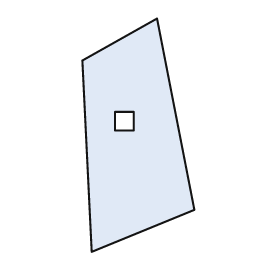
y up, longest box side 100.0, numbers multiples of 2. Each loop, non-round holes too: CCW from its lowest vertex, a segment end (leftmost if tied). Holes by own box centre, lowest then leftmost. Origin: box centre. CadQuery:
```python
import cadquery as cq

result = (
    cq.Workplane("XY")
    .moveTo(-20.0, -50.0)
    .lineTo(24.0, -32.0)
    .lineTo(8.0, 50.0)
    .lineTo(-24.0, 32.0)
    .close()
    .moveTo(-10.0, 2.0)
    .lineTo(-2.0, 2.0)
    .lineTo(-2.0, 10.0)
    .lineTo(-10.0, 10.0)
    .close()
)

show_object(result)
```